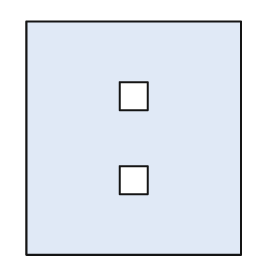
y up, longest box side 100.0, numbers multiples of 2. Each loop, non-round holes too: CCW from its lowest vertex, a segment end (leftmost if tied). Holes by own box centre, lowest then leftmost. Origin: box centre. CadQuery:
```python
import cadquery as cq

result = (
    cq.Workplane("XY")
    .moveTo(-46.0, -50.0)
    .lineTo(46.0, -50.0)
    .lineTo(46.0, 50.0)
    .lineTo(-46.0, 50.0)
    .close()
    .moveTo(-6.0, -24.0)
    .lineTo(6.0, -24.0)
    .lineTo(6.0, -12.0)
    .lineTo(-6.0, -12.0)
    .close()
    .moveTo(-6.0, 12.0)
    .lineTo(6.0, 12.0)
    .lineTo(6.0, 24.0)
    .lineTo(-6.0, 24.0)
    .close()
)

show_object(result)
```